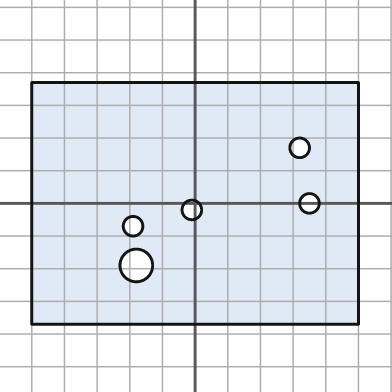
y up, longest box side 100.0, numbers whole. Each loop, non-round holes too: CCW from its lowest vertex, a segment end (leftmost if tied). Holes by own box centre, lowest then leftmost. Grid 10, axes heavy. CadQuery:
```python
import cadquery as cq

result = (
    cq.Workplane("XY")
    .moveTo(-50.0, -37.0)
    .lineTo(50.0, -37.0)
    .lineTo(50.0, 37.0)
    .lineTo(-50.0, 37.0)
    .close()
    .moveTo(-18.0, -19.0)
    .circle(5.0)
    .moveTo(-19.0, -7.0)
    .circle(3.0)
    .moveTo(-1.0, -2.0)
    .circle(3.0)
    .moveTo(35.0, 0.0)
    .circle(3.0)
    .moveTo(32.0, 17.0)
    .circle(3.0)
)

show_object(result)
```